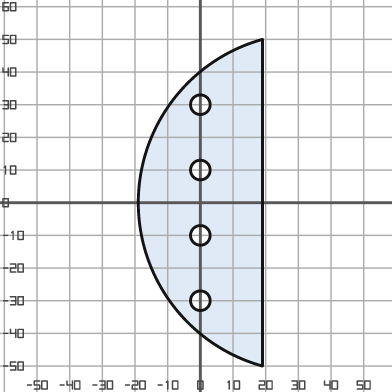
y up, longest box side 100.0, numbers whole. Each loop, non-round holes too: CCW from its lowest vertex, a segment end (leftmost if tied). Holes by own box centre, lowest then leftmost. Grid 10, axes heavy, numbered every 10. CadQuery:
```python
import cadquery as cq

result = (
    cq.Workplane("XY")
    .moveTo(19.0, -50.0)
    .lineTo(19.0, 50.0)
    .threePointArc((-19.0, 0.0), (19.0, -50.0))
    .close()
    .moveTo(0.0, -30.0)
    .circle(3.0)
    .moveTo(0.0, -10.0)
    .circle(3.0)
    .moveTo(0.0, 10.0)
    .circle(3.0)
    .moveTo(0.0, 30.0)
    .circle(3.0)
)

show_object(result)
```